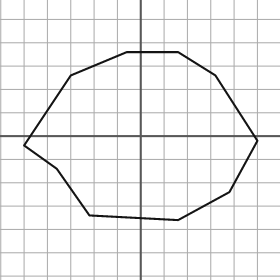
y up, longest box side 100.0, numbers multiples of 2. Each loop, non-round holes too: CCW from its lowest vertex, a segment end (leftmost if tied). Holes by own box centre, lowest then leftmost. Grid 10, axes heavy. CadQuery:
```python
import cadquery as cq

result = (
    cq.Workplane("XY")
    .moveTo(16.0, -36.0)
    .lineTo(38.0, -24.0)
    .lineTo(50.0, -2.0)
    .lineTo(32.0, 26.0)
    .lineTo(16.0, 36.0)
    .lineTo(-6.0, 36.0)
    .lineTo(-30.0, 26.0)
    .lineTo(-50.0, -4.0)
    .lineTo(-36.0, -14.0)
    .lineTo(-22.0, -34.0)
    .close()
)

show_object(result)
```